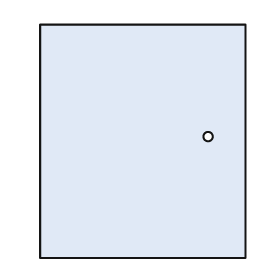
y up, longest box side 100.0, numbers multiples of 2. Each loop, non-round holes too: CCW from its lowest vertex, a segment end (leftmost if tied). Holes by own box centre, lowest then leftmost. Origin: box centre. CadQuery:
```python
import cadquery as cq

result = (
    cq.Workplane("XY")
    .moveTo(-44.0, -50.0)
    .lineTo(44.0, -50.0)
    .lineTo(44.0, 50.0)
    .lineTo(-44.0, 50.0)
    .close()
    .moveTo(28.0, 2.0)
    .circle(2.0)
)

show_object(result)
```